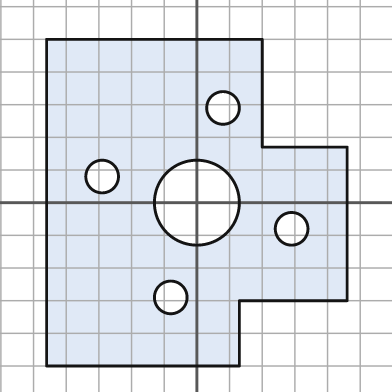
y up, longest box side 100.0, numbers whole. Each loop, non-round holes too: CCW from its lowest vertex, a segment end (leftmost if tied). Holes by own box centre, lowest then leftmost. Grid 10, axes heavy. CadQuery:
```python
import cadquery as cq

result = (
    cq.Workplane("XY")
    .moveTo(-46.0, -50.0)
    .lineTo(13.0, -50.0)
    .lineTo(13.0, -30.0)
    .lineTo(46.0, -30.0)
    .lineTo(46.0, 17.0)
    .lineTo(20.0, 17.0)
    .lineTo(20.0, 50.0)
    .lineTo(-46.0, 50.0)
    .close()
    .moveTo(-8.0, -29.0)
    .circle(5.0)
    .moveTo(29.0, -8.0)
    .circle(5.0)
    .moveTo(0.0, 0.0)
    .circle(13.0)
    .moveTo(-29.0, 8.0)
    .circle(5.0)
    .moveTo(8.0, 29.0)
    .circle(5.0)
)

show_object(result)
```